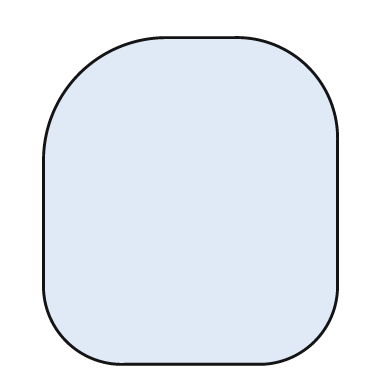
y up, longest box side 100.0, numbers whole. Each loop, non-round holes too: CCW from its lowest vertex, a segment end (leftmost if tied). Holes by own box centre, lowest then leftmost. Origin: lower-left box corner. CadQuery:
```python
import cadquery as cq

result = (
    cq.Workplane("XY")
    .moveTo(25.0, 0.0)
    .lineTo(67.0, 0.0)
    .threePointArc((83.0, 7.0), (90.0, 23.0))
    .lineTo(90.0, 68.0)
    .threePointArc((81.0, 91.0), (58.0, 100.0))
    .lineTo(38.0, 100.0)
    .threePointArc((11.0, 89.0), (0.0, 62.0))
    .lineTo(0.0, 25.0)
    .threePointArc((7.0, 7.0), (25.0, 0.0))
    .close()
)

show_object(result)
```